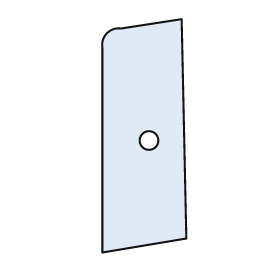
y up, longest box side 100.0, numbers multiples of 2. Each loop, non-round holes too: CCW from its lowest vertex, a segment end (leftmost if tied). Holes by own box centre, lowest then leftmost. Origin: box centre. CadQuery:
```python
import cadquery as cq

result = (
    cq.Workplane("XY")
    .moveTo(-18.0, -50.0)
    .lineTo(18.0, -44.0)
    .lineTo(16.0, 50.0)
    .lineTo(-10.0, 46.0)
    .threePointArc((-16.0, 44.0), (-18.0, 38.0))
    .close()
    .moveTo(2.0, -2.0)
    .circle(4.0)
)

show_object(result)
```